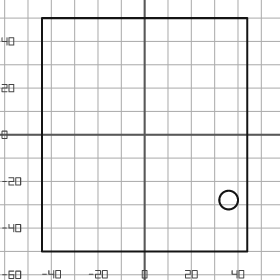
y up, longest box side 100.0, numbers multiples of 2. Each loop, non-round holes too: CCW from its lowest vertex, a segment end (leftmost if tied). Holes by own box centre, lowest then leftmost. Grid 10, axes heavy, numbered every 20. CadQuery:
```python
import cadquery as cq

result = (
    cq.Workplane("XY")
    .moveTo(-44.0, -50.0)
    .lineTo(44.0, -50.0)
    .lineTo(44.0, 50.0)
    .lineTo(-44.0, 50.0)
    .close()
    .moveTo(36.0, -28.0)
    .circle(4.0)
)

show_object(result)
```